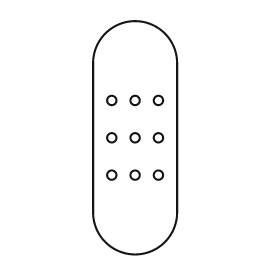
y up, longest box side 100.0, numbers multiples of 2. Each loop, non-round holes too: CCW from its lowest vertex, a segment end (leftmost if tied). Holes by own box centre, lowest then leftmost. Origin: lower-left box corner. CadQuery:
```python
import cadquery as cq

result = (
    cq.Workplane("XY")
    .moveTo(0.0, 18.0)
    .threePointArc((18.0, 0.0), (36.0, 18.0))
    .lineTo(36.0, 82.0)
    .threePointArc((18.0, 100.0), (0.0, 82.0))
    .close()
    .moveTo(8.0, 34.0)
    .circle(2.0)
    .moveTo(18.0, 34.0)
    .circle(2.0)
    .moveTo(28.0, 34.0)
    .circle(2.0)
    .moveTo(8.0, 50.0)
    .circle(2.0)
    .moveTo(18.0, 50.0)
    .circle(2.0)
    .moveTo(28.0, 50.0)
    .circle(2.0)
    .moveTo(8.0, 66.0)
    .circle(2.0)
    .moveTo(18.0, 66.0)
    .circle(2.0)
    .moveTo(28.0, 66.0)
    .circle(2.0)
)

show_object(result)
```